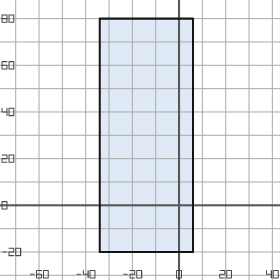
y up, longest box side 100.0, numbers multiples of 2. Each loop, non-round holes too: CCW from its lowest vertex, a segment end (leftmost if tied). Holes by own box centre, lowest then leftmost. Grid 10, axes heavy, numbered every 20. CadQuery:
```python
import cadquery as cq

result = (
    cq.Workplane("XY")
    .moveTo(-34.0, -20.0)
    .lineTo(6.0, -20.0)
    .lineTo(6.0, 80.0)
    .lineTo(-34.0, 80.0)
    .close()
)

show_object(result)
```